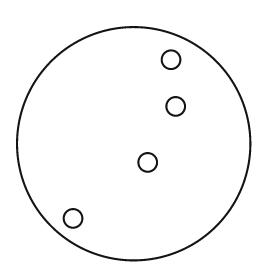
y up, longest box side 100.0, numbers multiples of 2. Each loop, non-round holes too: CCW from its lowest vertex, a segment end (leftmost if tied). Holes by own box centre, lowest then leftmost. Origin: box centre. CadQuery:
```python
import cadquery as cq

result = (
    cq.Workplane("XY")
    .moveTo(0.0, 0.0)
    .circle(50.0)
    .moveTo(-26.0, -32.0)
    .circle(4.0)
    .moveTo(6.0, -8.0)
    .circle(4.0)
    .moveTo(18.0, 16.0)
    .circle(4.0)
    .moveTo(16.0, 36.0)
    .circle(4.0)
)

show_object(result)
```